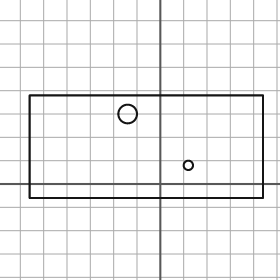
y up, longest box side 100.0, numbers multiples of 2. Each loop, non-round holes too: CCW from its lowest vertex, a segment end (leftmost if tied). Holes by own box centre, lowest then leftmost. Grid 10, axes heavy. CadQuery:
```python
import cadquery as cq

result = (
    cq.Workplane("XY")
    .moveTo(-56.0, -6.0)
    .lineTo(44.0, -6.0)
    .lineTo(44.0, 38.0)
    .lineTo(-56.0, 38.0)
    .close()
    .moveTo(12.0, 8.0)
    .circle(2.0)
    .moveTo(-14.0, 30.0)
    .circle(4.0)
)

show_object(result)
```